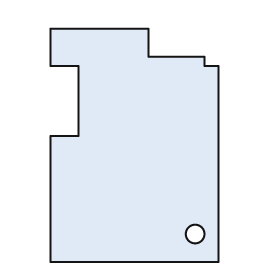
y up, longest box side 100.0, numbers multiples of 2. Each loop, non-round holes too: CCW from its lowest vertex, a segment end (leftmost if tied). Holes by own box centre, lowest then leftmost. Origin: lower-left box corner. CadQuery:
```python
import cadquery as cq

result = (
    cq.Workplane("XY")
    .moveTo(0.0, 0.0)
    .lineTo(72.0, 0.0)
    .lineTo(72.0, 84.0)
    .lineTo(66.0, 84.0)
    .lineTo(66.0, 88.0)
    .lineTo(42.0, 88.0)
    .lineTo(42.0, 100.0)
    .lineTo(0.0, 100.0)
    .lineTo(0.0, 84.0)
    .lineTo(12.0, 84.0)
    .lineTo(12.0, 54.0)
    .lineTo(0.0, 54.0)
    .close()
    .moveTo(62.0, 12.0)
    .circle(4.0)
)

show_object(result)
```